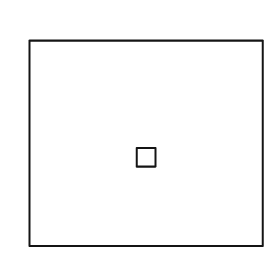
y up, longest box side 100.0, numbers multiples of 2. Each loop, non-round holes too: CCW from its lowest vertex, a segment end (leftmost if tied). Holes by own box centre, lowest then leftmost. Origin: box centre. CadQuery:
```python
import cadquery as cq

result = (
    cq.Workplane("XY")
    .moveTo(-50.0, -44.0)
    .lineTo(50.0, -44.0)
    .lineTo(50.0, 44.0)
    .lineTo(-50.0, 44.0)
    .close()
    .moveTo(-4.0, -10.0)
    .lineTo(4.0, -10.0)
    .lineTo(4.0, -2.0)
    .lineTo(-4.0, -2.0)
    .close()
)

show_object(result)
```